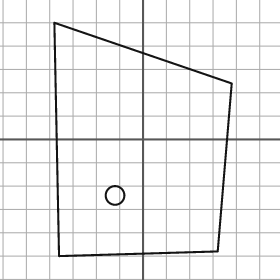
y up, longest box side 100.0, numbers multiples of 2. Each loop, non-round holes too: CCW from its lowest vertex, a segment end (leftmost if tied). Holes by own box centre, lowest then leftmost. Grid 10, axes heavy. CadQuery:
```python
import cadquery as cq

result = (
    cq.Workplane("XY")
    .moveTo(-36.0, -50.0)
    .lineTo(32.0, -48.0)
    .lineTo(38.0, 24.0)
    .lineTo(-38.0, 50.0)
    .close()
    .moveTo(-12.0, -24.0)
    .circle(4.0)
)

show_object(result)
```